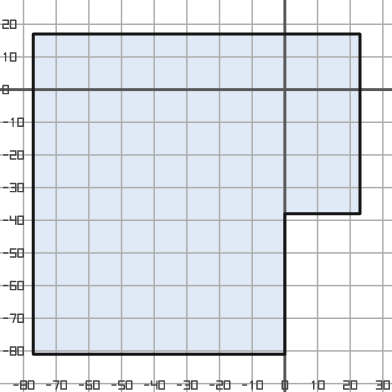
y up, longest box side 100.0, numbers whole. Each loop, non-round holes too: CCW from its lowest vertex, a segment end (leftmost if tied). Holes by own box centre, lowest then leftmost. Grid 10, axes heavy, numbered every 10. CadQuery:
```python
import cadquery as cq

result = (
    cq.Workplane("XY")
    .moveTo(-77.0, -81.0)
    .lineTo(0.0, -81.0)
    .lineTo(0.0, -38.0)
    .lineTo(23.0, -38.0)
    .lineTo(23.0, 17.0)
    .lineTo(-77.0, 17.0)
    .close()
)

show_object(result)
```